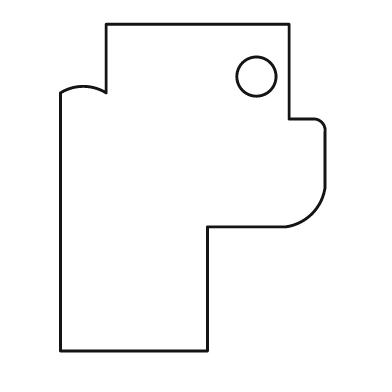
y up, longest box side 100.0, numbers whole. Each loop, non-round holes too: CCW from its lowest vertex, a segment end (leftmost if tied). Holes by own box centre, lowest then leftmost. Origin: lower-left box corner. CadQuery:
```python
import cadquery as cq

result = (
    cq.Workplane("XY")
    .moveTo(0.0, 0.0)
    .lineTo(45.0, 0.0)
    .lineTo(45.0, 38.0)
    .lineTo(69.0, 38.0)
    .threePointArc((77.0, 42.0), (81.0, 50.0))
    .lineTo(81.0, 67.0)
    .threePointArc((80.0, 70.0), (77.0, 71.0))
    .lineTo(70.0, 71.0)
    .lineTo(70.0, 100.0)
    .lineTo(14.0, 100.0)
    .lineTo(14.0, 79.0)
    .threePointArc((7.0, 81.0), (0.0, 79.0))
    .close()
    .moveTo(60.0, 84.0)
    .circle(6.0)
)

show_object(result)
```